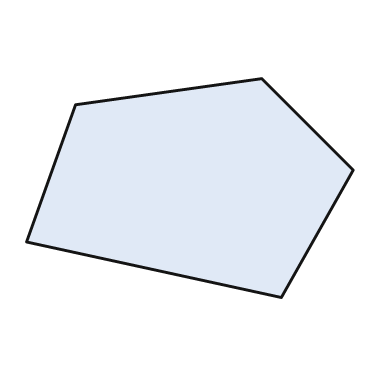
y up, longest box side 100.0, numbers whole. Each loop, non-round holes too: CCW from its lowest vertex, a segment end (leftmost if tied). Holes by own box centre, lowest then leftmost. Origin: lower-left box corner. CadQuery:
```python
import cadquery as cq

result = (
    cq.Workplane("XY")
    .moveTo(78.0, 0.0)
    .lineTo(100.0, 39.0)
    .lineTo(72.0, 67.0)
    .lineTo(15.0, 59.0)
    .lineTo(0.0, 17.0)
    .close()
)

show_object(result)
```